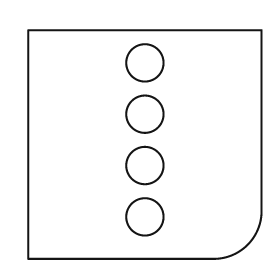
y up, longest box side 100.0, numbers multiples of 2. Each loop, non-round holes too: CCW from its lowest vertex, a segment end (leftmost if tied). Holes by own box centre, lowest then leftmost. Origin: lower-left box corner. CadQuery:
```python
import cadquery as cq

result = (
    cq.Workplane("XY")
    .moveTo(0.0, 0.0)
    .lineTo(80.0, 0.0)
    .threePointArc((94.0, 6.0), (100.0, 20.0))
    .lineTo(100.0, 98.0)
    .lineTo(0.0, 98.0)
    .close()
    .moveTo(50.0, 18.0)
    .circle(8.0)
    .moveTo(50.0, 40.0)
    .circle(8.0)
    .moveTo(50.0, 62.0)
    .circle(8.0)
    .moveTo(50.0, 84.0)
    .circle(8.0)
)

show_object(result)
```